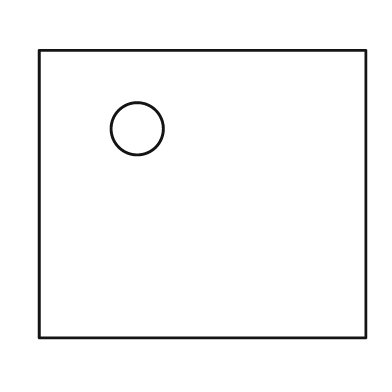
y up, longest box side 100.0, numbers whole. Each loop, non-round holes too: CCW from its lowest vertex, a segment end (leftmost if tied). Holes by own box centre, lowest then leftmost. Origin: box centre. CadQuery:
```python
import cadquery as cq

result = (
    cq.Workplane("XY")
    .moveTo(-50.0, -44.0)
    .lineTo(50.0, -44.0)
    .lineTo(50.0, 44.0)
    .lineTo(-50.0, 44.0)
    .close()
    .moveTo(-20.0, 20.0)
    .circle(8.0)
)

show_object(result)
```